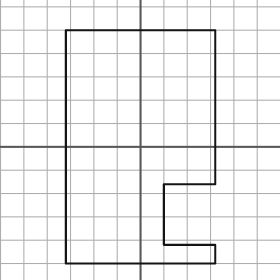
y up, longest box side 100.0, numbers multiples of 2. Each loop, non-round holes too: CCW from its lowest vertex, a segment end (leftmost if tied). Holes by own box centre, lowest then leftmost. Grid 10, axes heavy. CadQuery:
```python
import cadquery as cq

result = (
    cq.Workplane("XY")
    .moveTo(-32.0, -50.0)
    .lineTo(32.0, -50.0)
    .lineTo(32.0, -42.0)
    .lineTo(10.0, -42.0)
    .lineTo(10.0, -16.0)
    .lineTo(32.0, -16.0)
    .lineTo(32.0, 50.0)
    .lineTo(-32.0, 50.0)
    .close()
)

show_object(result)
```